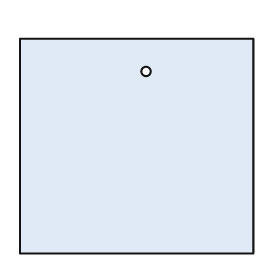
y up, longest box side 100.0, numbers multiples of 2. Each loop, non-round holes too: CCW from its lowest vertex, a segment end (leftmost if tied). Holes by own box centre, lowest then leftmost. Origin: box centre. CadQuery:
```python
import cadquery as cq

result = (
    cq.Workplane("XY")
    .moveTo(-50.0, -46.0)
    .lineTo(50.0, -46.0)
    .lineTo(50.0, 46.0)
    .lineTo(-50.0, 46.0)
    .close()
    .moveTo(4.0, 32.0)
    .circle(2.0)
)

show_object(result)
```